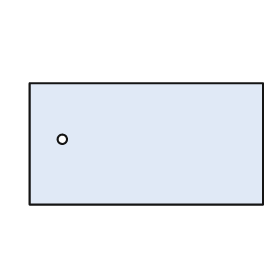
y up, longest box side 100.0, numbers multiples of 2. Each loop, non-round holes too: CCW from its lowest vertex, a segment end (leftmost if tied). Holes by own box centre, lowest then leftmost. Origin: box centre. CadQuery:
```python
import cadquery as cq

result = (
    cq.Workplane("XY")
    .moveTo(-50.0, -26.0)
    .lineTo(50.0, -26.0)
    .lineTo(50.0, 26.0)
    .lineTo(-50.0, 26.0)
    .close()
    .moveTo(-36.0, 2.0)
    .circle(2.0)
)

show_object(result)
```